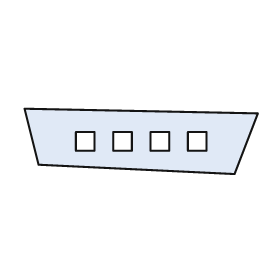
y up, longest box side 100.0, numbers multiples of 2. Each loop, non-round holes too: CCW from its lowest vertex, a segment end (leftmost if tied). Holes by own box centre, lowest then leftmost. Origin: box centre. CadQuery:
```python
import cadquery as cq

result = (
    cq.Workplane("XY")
    .moveTo(40.0, -14.0)
    .lineTo(50.0, 12.0)
    .lineTo(-50.0, 14.0)
    .lineTo(-44.0, -10.0)
    .close()
    .moveTo(-28.0, -4.0)
    .lineTo(-20.0, -4.0)
    .lineTo(-20.0, 4.0)
    .lineTo(-28.0, 4.0)
    .close()
    .moveTo(-12.0, -4.0)
    .lineTo(-4.0, -4.0)
    .lineTo(-4.0, 4.0)
    .lineTo(-12.0, 4.0)
    .close()
    .moveTo(4.0, -4.0)
    .lineTo(12.0, -4.0)
    .lineTo(12.0, 4.0)
    .lineTo(4.0, 4.0)
    .close()
    .moveTo(20.0, -4.0)
    .lineTo(28.0, -4.0)
    .lineTo(28.0, 4.0)
    .lineTo(20.0, 4.0)
    .close()
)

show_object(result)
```